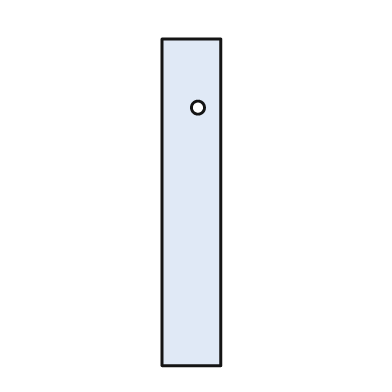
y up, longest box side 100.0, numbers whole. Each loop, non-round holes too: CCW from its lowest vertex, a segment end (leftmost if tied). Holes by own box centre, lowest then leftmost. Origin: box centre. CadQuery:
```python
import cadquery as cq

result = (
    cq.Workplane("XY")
    .moveTo(-9.0, -50.0)
    .lineTo(9.0, -50.0)
    .lineTo(9.0, 50.0)
    .lineTo(-9.0, 50.0)
    .close()
    .moveTo(2.0, 29.0)
    .circle(2.0)
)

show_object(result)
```